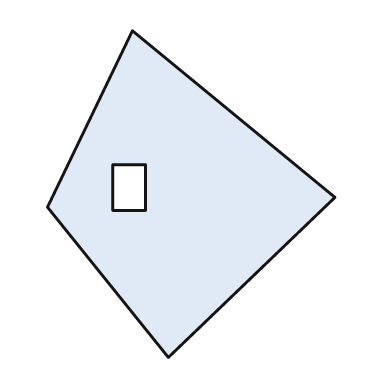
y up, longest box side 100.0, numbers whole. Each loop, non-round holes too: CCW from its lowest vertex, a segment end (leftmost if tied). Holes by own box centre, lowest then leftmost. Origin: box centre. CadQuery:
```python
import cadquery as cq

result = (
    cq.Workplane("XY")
    .moveTo(-7.0, -50.0)
    .lineTo(44.0, -1.0)
    .lineTo(-18.0, 50.0)
    .lineTo(-44.0, -4.0)
    .close()
    .moveTo(-24.0, -5.0)
    .lineTo(-14.0, -5.0)
    .lineTo(-14.0, 9.0)
    .lineTo(-24.0, 9.0)
    .close()
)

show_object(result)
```